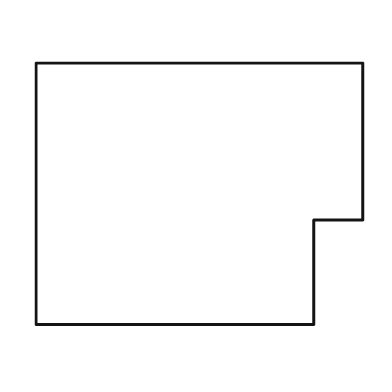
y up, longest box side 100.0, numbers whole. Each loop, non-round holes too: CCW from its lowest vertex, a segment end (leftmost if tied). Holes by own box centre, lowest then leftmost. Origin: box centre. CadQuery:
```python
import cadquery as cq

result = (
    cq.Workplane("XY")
    .moveTo(-50.0, -40.0)
    .lineTo(35.0, -40.0)
    .lineTo(35.0, -8.0)
    .lineTo(50.0, -8.0)
    .lineTo(50.0, 40.0)
    .lineTo(-50.0, 40.0)
    .close()
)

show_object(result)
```